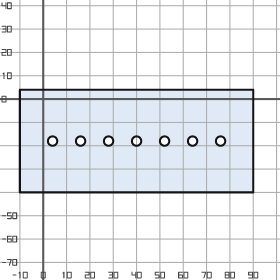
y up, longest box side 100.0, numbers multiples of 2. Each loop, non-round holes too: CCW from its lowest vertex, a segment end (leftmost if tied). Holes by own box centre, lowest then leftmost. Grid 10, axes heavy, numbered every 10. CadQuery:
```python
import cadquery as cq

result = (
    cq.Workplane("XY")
    .moveTo(-10.0, -40.0)
    .lineTo(90.0, -40.0)
    .lineTo(90.0, 4.0)
    .lineTo(-10.0, 4.0)
    .close()
    .moveTo(4.0, -18.0)
    .circle(2.0)
    .moveTo(16.0, -18.0)
    .circle(2.0)
    .moveTo(28.0, -18.0)
    .circle(2.0)
    .moveTo(40.0, -18.0)
    .circle(2.0)
    .moveTo(52.0, -18.0)
    .circle(2.0)
    .moveTo(64.0, -18.0)
    .circle(2.0)
    .moveTo(76.0, -18.0)
    .circle(2.0)
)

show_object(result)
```